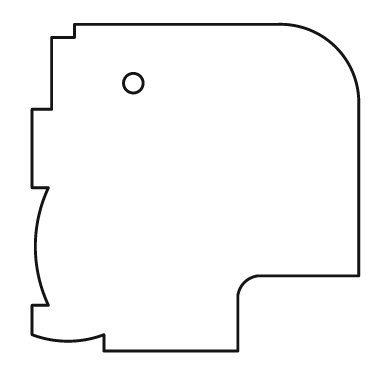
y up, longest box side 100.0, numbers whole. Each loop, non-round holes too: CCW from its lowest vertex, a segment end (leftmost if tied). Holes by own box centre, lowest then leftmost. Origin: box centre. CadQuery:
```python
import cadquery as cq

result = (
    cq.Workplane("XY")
    .moveTo(-28.0, -50.0)
    .lineTo(13.0, -50.0)
    .lineTo(13.0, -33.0)
    .threePointArc((15.0, -29.0), (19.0, -27.0))
    .lineTo(50.0, -27.0)
    .lineTo(50.0, 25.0)
    .threePointArc((43.0, 43.0), (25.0, 50.0))
    .lineTo(-37.0, 50.0)
    .lineTo(-37.0, 46.0)
    .lineTo(-44.0, 46.0)
    .lineTo(-44.0, 24.0)
    .lineTo(-50.0, 24.0)
    .lineTo(-50.0, 0.0)
    .lineTo(-45.0, 0.0)
    .threePointArc((-49.0, -18.0), (-45.0, -36.0))
    .lineTo(-50.0, -36.0)
    .lineTo(-50.0, -45.0)
    .threePointArc((-39.0, -47.0), (-28.0, -45.0))
    .close()
    .moveTo(-19.0, 32.0)
    .circle(3.0)
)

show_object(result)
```